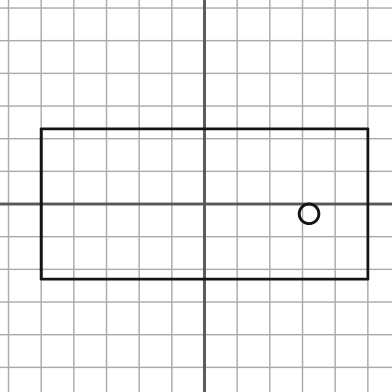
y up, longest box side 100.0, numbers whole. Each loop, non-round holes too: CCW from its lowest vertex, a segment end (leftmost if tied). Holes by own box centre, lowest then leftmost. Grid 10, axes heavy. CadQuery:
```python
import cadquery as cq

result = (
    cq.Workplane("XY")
    .moveTo(-50.0, -23.0)
    .lineTo(50.0, -23.0)
    .lineTo(50.0, 23.0)
    .lineTo(-50.0, 23.0)
    .close()
    .moveTo(32.0, -3.0)
    .circle(3.0)
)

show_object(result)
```